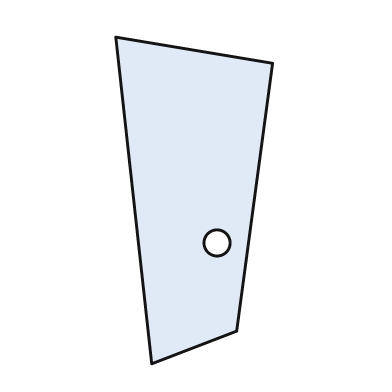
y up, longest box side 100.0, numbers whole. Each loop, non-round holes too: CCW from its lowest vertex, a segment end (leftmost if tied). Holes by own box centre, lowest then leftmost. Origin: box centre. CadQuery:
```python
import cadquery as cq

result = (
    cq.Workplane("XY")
    .moveTo(-13.0, -50.0)
    .lineTo(13.0, -40.0)
    .lineTo(24.0, 42.0)
    .lineTo(-24.0, 50.0)
    .close()
    .moveTo(7.0, -13.0)
    .circle(4.0)
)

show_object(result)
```